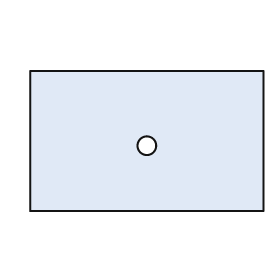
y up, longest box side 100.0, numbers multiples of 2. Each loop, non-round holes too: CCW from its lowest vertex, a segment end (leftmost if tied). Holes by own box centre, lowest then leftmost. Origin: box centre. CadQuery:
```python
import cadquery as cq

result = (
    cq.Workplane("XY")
    .moveTo(-50.0, -30.0)
    .lineTo(50.0, -30.0)
    .lineTo(50.0, 30.0)
    .lineTo(-50.0, 30.0)
    .close()
    .moveTo(0.0, -2.0)
    .circle(4.0)
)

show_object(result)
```